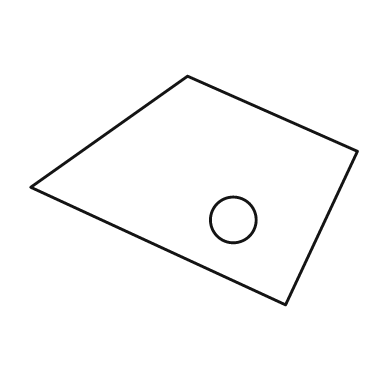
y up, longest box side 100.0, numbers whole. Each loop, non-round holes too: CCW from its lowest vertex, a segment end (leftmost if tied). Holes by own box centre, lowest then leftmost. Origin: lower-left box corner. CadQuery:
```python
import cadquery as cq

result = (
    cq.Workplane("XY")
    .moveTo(78.0, 0.0)
    .lineTo(100.0, 47.0)
    .lineTo(48.0, 70.0)
    .lineTo(0.0, 36.0)
    .close()
    .moveTo(62.0, 26.0)
    .circle(7.0)
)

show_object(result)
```